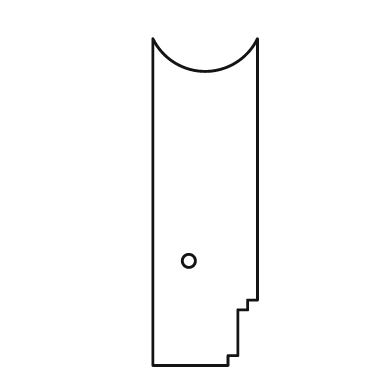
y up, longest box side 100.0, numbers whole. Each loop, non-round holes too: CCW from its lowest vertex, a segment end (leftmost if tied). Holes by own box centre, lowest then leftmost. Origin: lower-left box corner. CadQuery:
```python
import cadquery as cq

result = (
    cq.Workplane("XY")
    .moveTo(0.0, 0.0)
    .lineTo(23.0, 0.0)
    .lineTo(23.0, 3.0)
    .lineTo(26.0, 3.0)
    .lineTo(26.0, 17.0)
    .lineTo(29.0, 17.0)
    .lineTo(29.0, 20.0)
    .lineTo(32.0, 20.0)
    .lineTo(32.0, 100.0)
    .threePointArc((16.0, 90.0), (0.0, 100.0))
    .close()
    .moveTo(11.0, 32.0)
    .circle(2.0)
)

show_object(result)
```